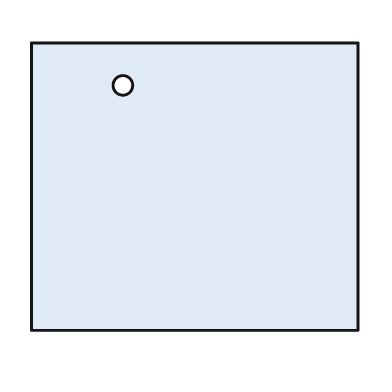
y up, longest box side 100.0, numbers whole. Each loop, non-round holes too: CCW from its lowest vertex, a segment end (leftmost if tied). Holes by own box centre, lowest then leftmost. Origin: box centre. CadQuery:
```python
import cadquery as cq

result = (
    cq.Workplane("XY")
    .moveTo(-50.0, -44.0)
    .lineTo(50.0, -44.0)
    .lineTo(50.0, 44.0)
    .lineTo(-50.0, 44.0)
    .close()
    .moveTo(-22.0, 31.0)
    .circle(3.0)
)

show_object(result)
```